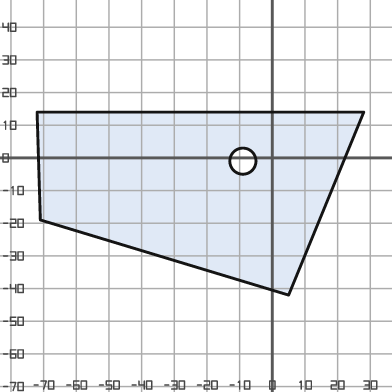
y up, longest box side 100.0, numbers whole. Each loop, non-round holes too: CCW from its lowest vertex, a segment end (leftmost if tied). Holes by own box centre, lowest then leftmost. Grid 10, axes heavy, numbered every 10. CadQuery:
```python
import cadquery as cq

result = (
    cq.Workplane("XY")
    .moveTo(5.0, -42.0)
    .lineTo(28.0, 14.0)
    .lineTo(-72.0, 14.0)
    .lineTo(-71.0, -19.0)
    .close()
    .moveTo(-9.0, -1.0)
    .circle(4.0)
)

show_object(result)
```